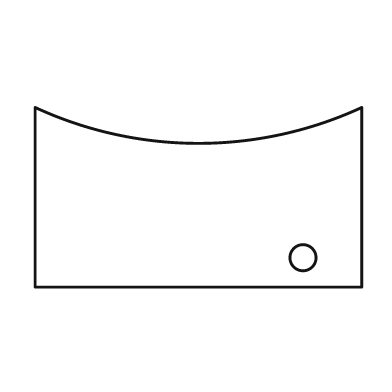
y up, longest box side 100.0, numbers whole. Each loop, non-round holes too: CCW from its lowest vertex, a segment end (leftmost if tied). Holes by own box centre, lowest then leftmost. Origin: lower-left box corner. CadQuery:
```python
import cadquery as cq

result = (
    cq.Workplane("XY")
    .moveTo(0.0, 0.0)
    .lineTo(100.0, 0.0)
    .lineTo(100.0, 55.0)
    .threePointArc((50.0, 44.0), (0.0, 55.0))
    .close()
    .moveTo(82.0, 9.0)
    .circle(4.0)
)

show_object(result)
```